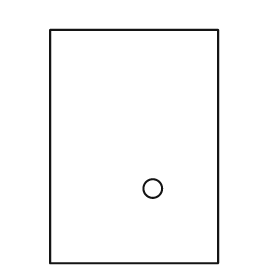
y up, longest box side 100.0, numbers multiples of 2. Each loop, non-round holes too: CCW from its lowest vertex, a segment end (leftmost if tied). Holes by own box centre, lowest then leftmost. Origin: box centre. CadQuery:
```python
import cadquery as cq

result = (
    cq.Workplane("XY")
    .moveTo(-36.0, -50.0)
    .lineTo(36.0, -50.0)
    .lineTo(36.0, 50.0)
    .lineTo(-36.0, 50.0)
    .close()
    .moveTo(8.0, -18.0)
    .circle(4.0)
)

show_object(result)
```